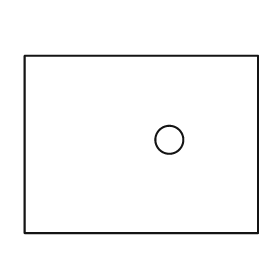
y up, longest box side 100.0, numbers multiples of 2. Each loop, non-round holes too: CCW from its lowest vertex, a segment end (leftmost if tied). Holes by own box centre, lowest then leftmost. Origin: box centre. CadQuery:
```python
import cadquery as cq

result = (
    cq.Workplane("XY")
    .moveTo(-50.0, -38.0)
    .lineTo(50.0, -38.0)
    .lineTo(50.0, 38.0)
    .lineTo(-50.0, 38.0)
    .close()
    .moveTo(12.0, 2.0)
    .circle(6.0)
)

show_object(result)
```